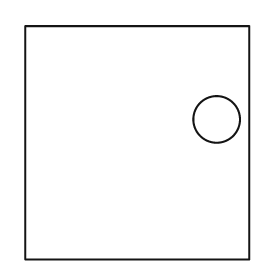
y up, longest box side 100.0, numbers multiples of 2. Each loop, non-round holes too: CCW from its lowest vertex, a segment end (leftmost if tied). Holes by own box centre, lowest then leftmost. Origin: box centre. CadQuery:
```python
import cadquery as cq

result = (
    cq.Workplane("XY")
    .moveTo(-48.0, -50.0)
    .lineTo(48.0, -50.0)
    .lineTo(48.0, 50.0)
    .lineTo(-48.0, 50.0)
    .close()
    .moveTo(34.0, 10.0)
    .circle(10.0)
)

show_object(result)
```